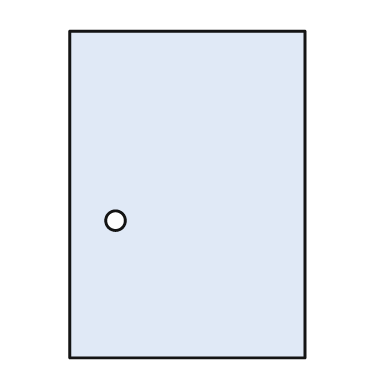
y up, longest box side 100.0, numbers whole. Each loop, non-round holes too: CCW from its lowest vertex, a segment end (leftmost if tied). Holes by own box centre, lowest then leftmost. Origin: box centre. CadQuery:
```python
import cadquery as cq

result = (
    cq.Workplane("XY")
    .moveTo(-36.0, -50.0)
    .lineTo(36.0, -50.0)
    .lineTo(36.0, 50.0)
    .lineTo(-36.0, 50.0)
    .close()
    .moveTo(-22.0, -8.0)
    .circle(3.0)
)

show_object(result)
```